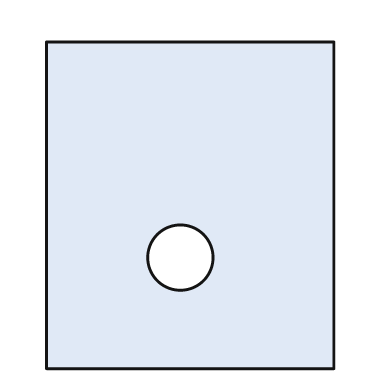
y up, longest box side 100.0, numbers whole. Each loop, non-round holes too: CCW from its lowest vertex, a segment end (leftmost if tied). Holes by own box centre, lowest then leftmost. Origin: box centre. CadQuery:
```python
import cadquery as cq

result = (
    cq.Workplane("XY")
    .moveTo(-44.0, -50.0)
    .lineTo(44.0, -50.0)
    .lineTo(44.0, 50.0)
    .lineTo(-44.0, 50.0)
    .close()
    .moveTo(-3.0, -16.0)
    .circle(10.0)
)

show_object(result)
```